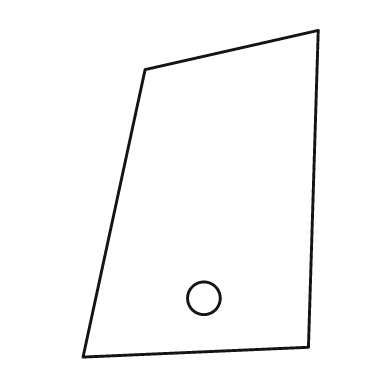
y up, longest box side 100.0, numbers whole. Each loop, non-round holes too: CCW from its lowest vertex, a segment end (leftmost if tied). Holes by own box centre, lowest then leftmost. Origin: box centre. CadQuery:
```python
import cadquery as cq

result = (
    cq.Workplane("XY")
    .moveTo(-36.0, -50.0)
    .lineTo(33.0, -47.0)
    .lineTo(36.0, 50.0)
    .lineTo(-17.0, 38.0)
    .close()
    .moveTo(1.0, -32.0)
    .circle(5.0)
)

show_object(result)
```